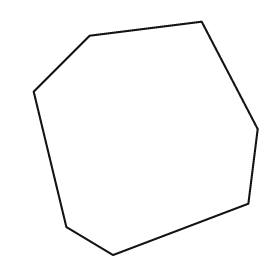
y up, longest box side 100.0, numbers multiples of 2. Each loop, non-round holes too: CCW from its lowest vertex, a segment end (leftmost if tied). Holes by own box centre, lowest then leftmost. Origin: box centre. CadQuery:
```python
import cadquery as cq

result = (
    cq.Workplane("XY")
    .moveTo(-14.0, -50.0)
    .lineTo(44.0, -28.0)
    .lineTo(48.0, 4.0)
    .lineTo(24.0, 50.0)
    .lineTo(-24.0, 44.0)
    .lineTo(-48.0, 20.0)
    .lineTo(-34.0, -38.0)
    .close()
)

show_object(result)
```